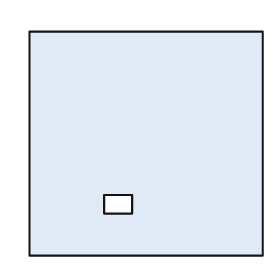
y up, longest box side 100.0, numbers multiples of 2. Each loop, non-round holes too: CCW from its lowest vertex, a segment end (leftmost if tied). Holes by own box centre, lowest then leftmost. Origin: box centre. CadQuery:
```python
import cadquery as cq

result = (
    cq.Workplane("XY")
    .moveTo(-50.0, -48.0)
    .lineTo(50.0, -48.0)
    .lineTo(50.0, 48.0)
    .lineTo(-50.0, 48.0)
    .close()
    .moveTo(-18.0, -30.0)
    .lineTo(-6.0, -30.0)
    .lineTo(-6.0, -22.0)
    .lineTo(-18.0, -22.0)
    .close()
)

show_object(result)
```